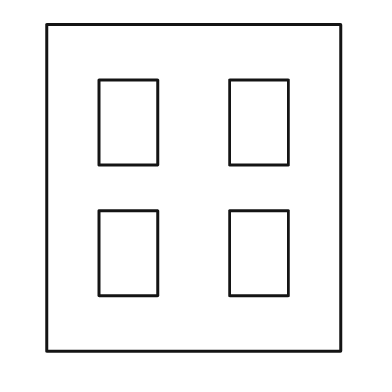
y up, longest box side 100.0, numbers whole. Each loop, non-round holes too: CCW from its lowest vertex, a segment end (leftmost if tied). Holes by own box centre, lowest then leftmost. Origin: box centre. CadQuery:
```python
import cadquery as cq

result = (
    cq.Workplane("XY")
    .moveTo(-45.0, -50.0)
    .lineTo(45.0, -50.0)
    .lineTo(45.0, 50.0)
    .lineTo(-45.0, 50.0)
    .close()
    .moveTo(-29.0, -33.0)
    .lineTo(-11.0, -33.0)
    .lineTo(-11.0, -7.0)
    .lineTo(-29.0, -7.0)
    .close()
    .moveTo(11.0, -33.0)
    .lineTo(29.0, -33.0)
    .lineTo(29.0, -7.0)
    .lineTo(11.0, -7.0)
    .close()
    .moveTo(-29.0, 7.0)
    .lineTo(-11.0, 7.0)
    .lineTo(-11.0, 33.0)
    .lineTo(-29.0, 33.0)
    .close()
    .moveTo(11.0, 7.0)
    .lineTo(29.0, 7.0)
    .lineTo(29.0, 33.0)
    .lineTo(11.0, 33.0)
    .close()
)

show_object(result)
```